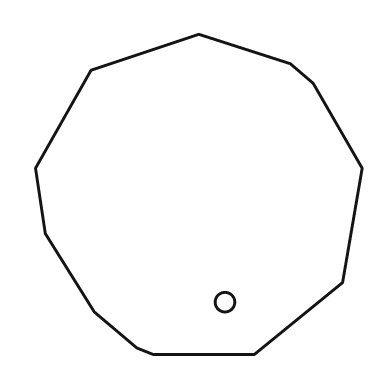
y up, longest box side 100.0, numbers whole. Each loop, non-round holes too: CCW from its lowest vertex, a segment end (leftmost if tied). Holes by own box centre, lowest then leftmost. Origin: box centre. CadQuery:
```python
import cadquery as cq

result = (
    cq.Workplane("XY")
    .moveTo(-14.0, -49.0)
    .lineTo(17.0, -49.0)
    .lineTo(44.0, -27.0)
    .lineTo(50.0, 8.0)
    .lineTo(35.0, 34.0)
    .lineTo(28.0, 40.0)
    .lineTo(0.0, 49.0)
    .lineTo(-33.0, 38.0)
    .lineTo(-50.0, 8.0)
    .lineTo(-47.0, -12.0)
    .lineTo(-32.0, -36.0)
    .lineTo(-19.0, -47.0)
    .close()
    .moveTo(8.0, -33.0)
    .circle(3.0)
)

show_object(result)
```